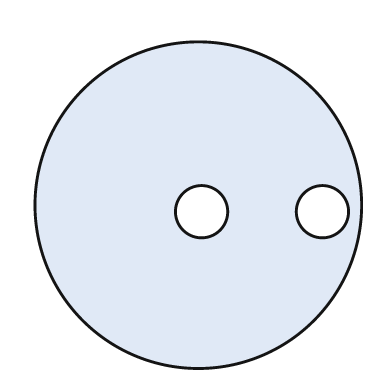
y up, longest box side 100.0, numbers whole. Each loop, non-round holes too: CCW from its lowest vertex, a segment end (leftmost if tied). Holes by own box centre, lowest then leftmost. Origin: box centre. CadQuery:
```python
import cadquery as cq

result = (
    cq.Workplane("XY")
    .moveTo(0.0, 0.0)
    .circle(50.0)
    .moveTo(1.0, -2.0)
    .circle(8.0)
    .moveTo(38.0, -2.0)
    .circle(8.0)
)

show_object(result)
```